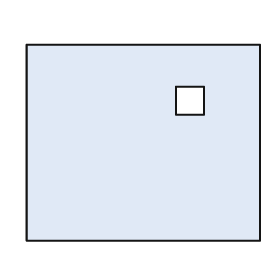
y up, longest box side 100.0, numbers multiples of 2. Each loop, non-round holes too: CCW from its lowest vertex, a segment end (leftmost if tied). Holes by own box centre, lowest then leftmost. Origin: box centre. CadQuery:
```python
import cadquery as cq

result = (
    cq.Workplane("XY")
    .moveTo(-50.0, -42.0)
    .lineTo(50.0, -42.0)
    .lineTo(50.0, 42.0)
    .lineTo(-50.0, 42.0)
    .close()
    .moveTo(14.0, 12.0)
    .lineTo(26.0, 12.0)
    .lineTo(26.0, 24.0)
    .lineTo(14.0, 24.0)
    .close()
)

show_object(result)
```